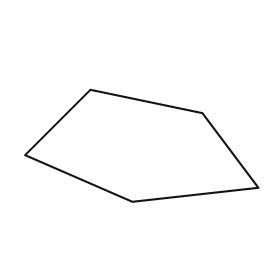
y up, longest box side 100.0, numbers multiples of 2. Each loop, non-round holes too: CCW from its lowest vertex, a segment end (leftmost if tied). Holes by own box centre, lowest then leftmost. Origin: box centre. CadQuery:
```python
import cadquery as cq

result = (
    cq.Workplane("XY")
    .moveTo(-4.0, -24.0)
    .lineTo(50.0, -18.0)
    .lineTo(26.0, 14.0)
    .lineTo(-22.0, 24.0)
    .lineTo(-50.0, -4.0)
    .close()
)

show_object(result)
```